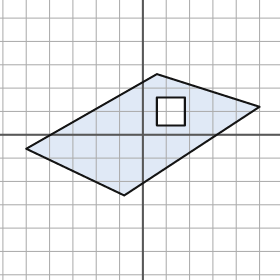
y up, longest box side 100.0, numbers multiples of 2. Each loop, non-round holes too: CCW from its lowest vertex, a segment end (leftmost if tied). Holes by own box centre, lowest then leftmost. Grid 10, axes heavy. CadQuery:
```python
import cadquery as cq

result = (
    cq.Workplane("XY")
    .moveTo(-8.0, -26.0)
    .lineTo(50.0, 12.0)
    .lineTo(6.0, 26.0)
    .lineTo(-50.0, -6.0)
    .close()
    .moveTo(6.0, 4.0)
    .lineTo(18.0, 4.0)
    .lineTo(18.0, 16.0)
    .lineTo(6.0, 16.0)
    .close()
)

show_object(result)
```